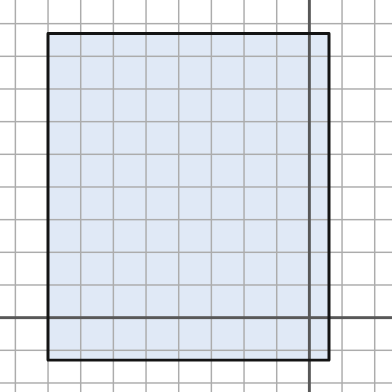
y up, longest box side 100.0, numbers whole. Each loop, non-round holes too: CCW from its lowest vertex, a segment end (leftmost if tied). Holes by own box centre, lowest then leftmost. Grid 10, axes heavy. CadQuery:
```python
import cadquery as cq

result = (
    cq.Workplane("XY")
    .moveTo(-80.0, -13.0)
    .lineTo(6.0, -13.0)
    .lineTo(6.0, 87.0)
    .lineTo(-80.0, 87.0)
    .close()
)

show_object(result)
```